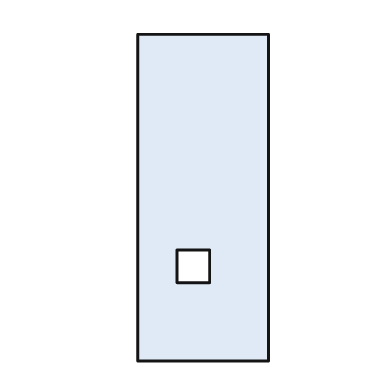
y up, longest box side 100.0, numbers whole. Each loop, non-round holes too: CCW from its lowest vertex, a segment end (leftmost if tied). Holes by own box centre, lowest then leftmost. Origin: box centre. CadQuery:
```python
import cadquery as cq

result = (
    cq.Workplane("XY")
    .moveTo(-20.0, -50.0)
    .lineTo(20.0, -50.0)
    .lineTo(20.0, 50.0)
    .lineTo(-20.0, 50.0)
    .close()
    .moveTo(-8.0, -26.0)
    .lineTo(2.0, -26.0)
    .lineTo(2.0, -16.0)
    .lineTo(-8.0, -16.0)
    .close()
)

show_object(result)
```